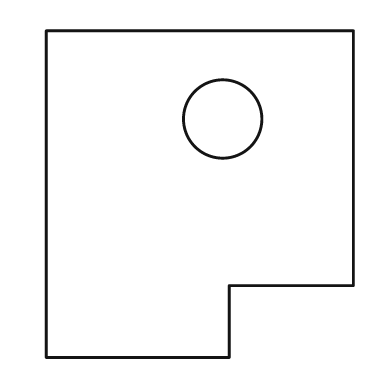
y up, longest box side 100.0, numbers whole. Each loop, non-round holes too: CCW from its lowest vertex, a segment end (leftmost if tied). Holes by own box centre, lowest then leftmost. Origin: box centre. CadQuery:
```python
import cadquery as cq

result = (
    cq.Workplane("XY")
    .moveTo(-47.0, -50.0)
    .lineTo(9.0, -50.0)
    .lineTo(9.0, -28.0)
    .lineTo(47.0, -28.0)
    .lineTo(47.0, 50.0)
    .lineTo(-47.0, 50.0)
    .close()
    .moveTo(7.0, 23.0)
    .circle(12.0)
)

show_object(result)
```